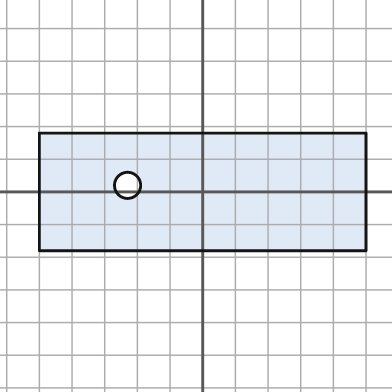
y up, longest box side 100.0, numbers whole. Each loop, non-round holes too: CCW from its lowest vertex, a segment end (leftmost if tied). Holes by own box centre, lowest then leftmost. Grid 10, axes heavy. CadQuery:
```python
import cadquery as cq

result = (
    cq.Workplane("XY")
    .moveTo(-50.0, -18.0)
    .lineTo(50.0, -18.0)
    .lineTo(50.0, 18.0)
    .lineTo(-50.0, 18.0)
    .close()
    .moveTo(-23.0, 2.0)
    .circle(4.0)
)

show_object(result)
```